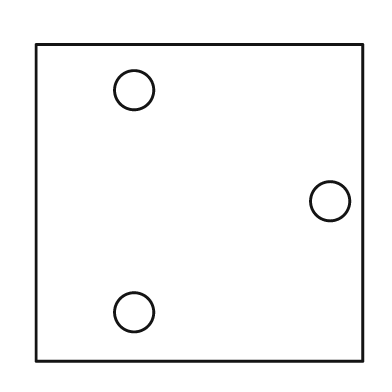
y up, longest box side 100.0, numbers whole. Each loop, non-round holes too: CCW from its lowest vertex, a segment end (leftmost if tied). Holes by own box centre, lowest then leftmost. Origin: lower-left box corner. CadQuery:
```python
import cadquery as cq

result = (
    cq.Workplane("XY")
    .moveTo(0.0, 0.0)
    .lineTo(100.0, 0.0)
    .lineTo(100.0, 97.0)
    .lineTo(0.0, 97.0)
    .close()
    .moveTo(30.0, 15.0)
    .circle(6.0)
    .moveTo(90.0, 49.0)
    .circle(6.0)
    .moveTo(30.0, 83.0)
    .circle(6.0)
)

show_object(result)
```